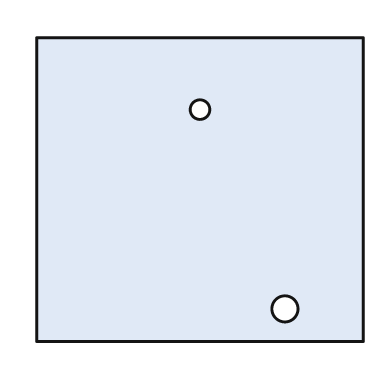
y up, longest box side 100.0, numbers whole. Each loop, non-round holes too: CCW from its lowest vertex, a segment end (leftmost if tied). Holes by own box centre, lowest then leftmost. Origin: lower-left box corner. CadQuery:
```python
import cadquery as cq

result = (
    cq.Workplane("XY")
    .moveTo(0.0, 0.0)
    .lineTo(100.0, 0.0)
    .lineTo(100.0, 93.0)
    .lineTo(0.0, 93.0)
    .close()
    .moveTo(76.0, 10.0)
    .circle(4.0)
    .moveTo(50.0, 71.0)
    .circle(3.0)
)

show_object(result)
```